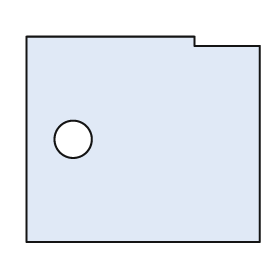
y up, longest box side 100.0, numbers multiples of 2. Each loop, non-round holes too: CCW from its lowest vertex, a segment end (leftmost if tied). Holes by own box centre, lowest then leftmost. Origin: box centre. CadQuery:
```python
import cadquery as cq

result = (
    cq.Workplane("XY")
    .moveTo(-50.0, -44.0)
    .lineTo(50.0, -44.0)
    .lineTo(50.0, 40.0)
    .lineTo(22.0, 40.0)
    .lineTo(22.0, 44.0)
    .lineTo(-50.0, 44.0)
    .close()
    .moveTo(-30.0, 0.0)
    .circle(8.0)
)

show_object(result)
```